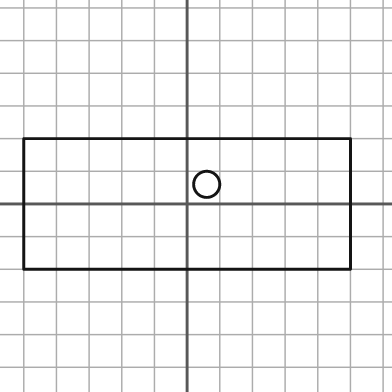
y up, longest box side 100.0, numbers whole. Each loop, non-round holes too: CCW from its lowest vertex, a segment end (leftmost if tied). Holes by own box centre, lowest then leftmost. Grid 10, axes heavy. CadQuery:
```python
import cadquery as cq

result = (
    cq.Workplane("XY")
    .moveTo(-50.0, -20.0)
    .lineTo(50.0, -20.0)
    .lineTo(50.0, 20.0)
    .lineTo(-50.0, 20.0)
    .close()
    .moveTo(6.0, 6.0)
    .circle(4.0)
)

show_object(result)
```